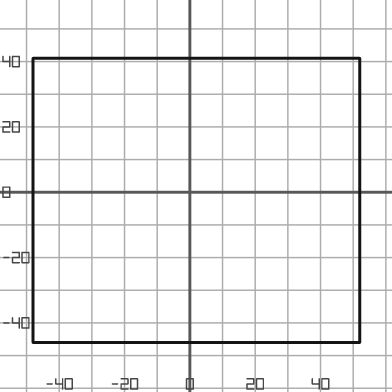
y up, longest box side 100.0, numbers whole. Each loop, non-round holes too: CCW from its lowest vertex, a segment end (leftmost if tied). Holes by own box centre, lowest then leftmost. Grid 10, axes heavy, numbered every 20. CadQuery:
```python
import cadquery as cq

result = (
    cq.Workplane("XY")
    .moveTo(-48.0, -46.0)
    .lineTo(52.0, -46.0)
    .lineTo(52.0, 41.0)
    .lineTo(-48.0, 41.0)
    .close()
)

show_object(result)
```